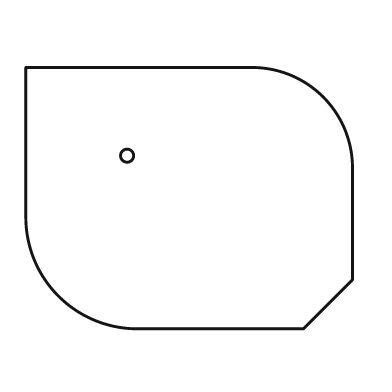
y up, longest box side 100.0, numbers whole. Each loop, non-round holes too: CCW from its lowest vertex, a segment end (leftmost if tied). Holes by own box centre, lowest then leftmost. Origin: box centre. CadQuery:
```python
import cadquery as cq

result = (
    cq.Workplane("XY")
    .moveTo(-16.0, -40.0)
    .lineTo(35.0, -40.0)
    .lineTo(50.0, -25.0)
    .lineTo(50.0, 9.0)
    .threePointArc((41.0, 31.0), (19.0, 40.0))
    .lineTo(-50.0, 40.0)
    .lineTo(-50.0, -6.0)
    .threePointArc((-40.0, -30.0), (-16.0, -40.0))
    .close()
    .moveTo(-19.0, 13.0)
    .circle(2.0)
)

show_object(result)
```